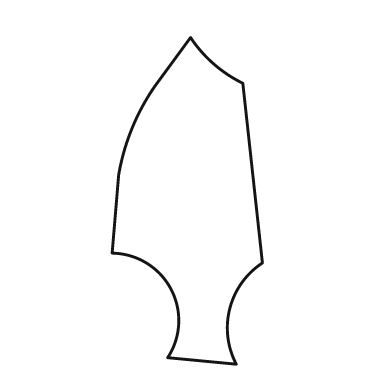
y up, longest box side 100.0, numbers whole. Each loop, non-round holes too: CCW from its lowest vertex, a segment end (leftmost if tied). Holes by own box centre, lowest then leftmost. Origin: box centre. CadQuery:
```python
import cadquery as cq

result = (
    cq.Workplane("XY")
    .moveTo(15.0, -50.0)
    .threePointArc((13.0, -33.0), (23.0, -19.0))
    .lineTo(17.0, 36.0)
    .threePointArc((8.0, 42.0), (1.0, 50.0))
    .lineTo(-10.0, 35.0)
    .threePointArc((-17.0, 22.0), (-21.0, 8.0))
    .lineTo(-23.0, -16.0)
    .threePointArc((-5.0, -27.0), (-6.0, -48.0))
    .close()
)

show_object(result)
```